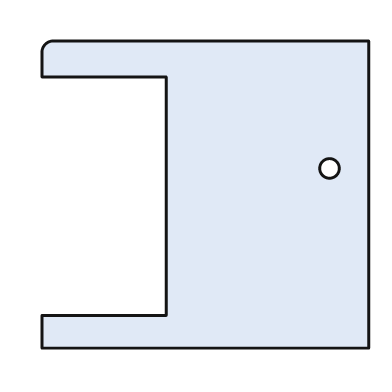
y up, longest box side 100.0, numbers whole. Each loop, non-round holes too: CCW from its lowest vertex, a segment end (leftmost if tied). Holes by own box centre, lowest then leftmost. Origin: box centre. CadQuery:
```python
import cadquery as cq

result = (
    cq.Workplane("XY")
    .moveTo(-50.0, -47.0)
    .lineTo(50.0, -47.0)
    .lineTo(50.0, 47.0)
    .lineTo(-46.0, 47.0)
    .threePointArc((-49.0, 46.0), (-50.0, 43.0))
    .lineTo(-50.0, 36.0)
    .lineTo(-12.0, 36.0)
    .lineTo(-12.0, -37.0)
    .lineTo(-50.0, -37.0)
    .close()
    .moveTo(38.0, 8.0)
    .circle(3.0)
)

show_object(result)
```